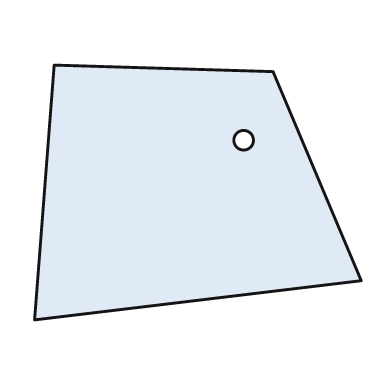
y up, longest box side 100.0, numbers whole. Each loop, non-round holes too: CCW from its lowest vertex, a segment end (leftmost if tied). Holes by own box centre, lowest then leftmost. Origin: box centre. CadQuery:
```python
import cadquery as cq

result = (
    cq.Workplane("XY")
    .moveTo(-50.0, -39.0)
    .lineTo(50.0, -27.0)
    .lineTo(23.0, 37.0)
    .lineTo(-44.0, 39.0)
    .close()
    .moveTo(14.0, 16.0)
    .circle(3.0)
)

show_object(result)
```